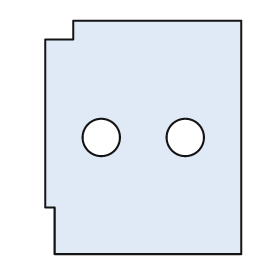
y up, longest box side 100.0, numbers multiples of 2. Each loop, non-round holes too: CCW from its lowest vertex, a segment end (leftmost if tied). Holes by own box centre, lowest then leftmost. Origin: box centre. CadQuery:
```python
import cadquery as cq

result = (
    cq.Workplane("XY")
    .moveTo(-38.0, -50.0)
    .lineTo(42.0, -50.0)
    .lineTo(42.0, 50.0)
    .lineTo(-30.0, 50.0)
    .lineTo(-30.0, 42.0)
    .lineTo(-42.0, 42.0)
    .lineTo(-42.0, -30.0)
    .lineTo(-38.0, -30.0)
    .close()
    .moveTo(-18.0, 0.0)
    .circle(8.0)
    .moveTo(18.0, 0.0)
    .circle(8.0)
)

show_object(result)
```